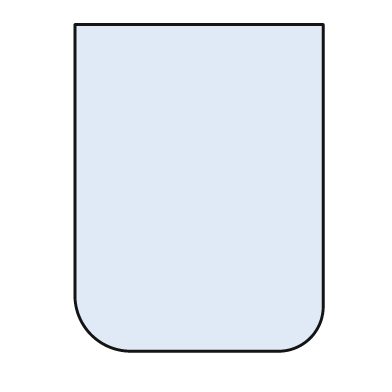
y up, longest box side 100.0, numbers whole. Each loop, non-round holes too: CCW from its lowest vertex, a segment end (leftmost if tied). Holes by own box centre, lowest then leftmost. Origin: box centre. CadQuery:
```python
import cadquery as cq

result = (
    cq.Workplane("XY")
    .moveTo(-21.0, -50.0)
    .lineTo(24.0, -50.0)
    .threePointArc((34.0, -46.0), (38.0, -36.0))
    .lineTo(38.0, 50.0)
    .lineTo(-38.0, 50.0)
    .lineTo(-38.0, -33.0)
    .threePointArc((-33.0, -45.0), (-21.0, -50.0))
    .close()
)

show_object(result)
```